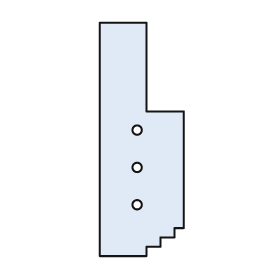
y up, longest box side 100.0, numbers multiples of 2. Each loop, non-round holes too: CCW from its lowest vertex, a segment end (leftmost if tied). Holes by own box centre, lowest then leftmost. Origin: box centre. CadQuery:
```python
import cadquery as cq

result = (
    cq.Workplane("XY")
    .moveTo(-18.0, -50.0)
    .lineTo(2.0, -50.0)
    .lineTo(2.0, -46.0)
    .lineTo(8.0, -46.0)
    .lineTo(8.0, -42.0)
    .lineTo(14.0, -42.0)
    .lineTo(14.0, -38.0)
    .lineTo(18.0, -38.0)
    .lineTo(18.0, 12.0)
    .lineTo(2.0, 12.0)
    .lineTo(2.0, 50.0)
    .lineTo(-18.0, 50.0)
    .close()
    .moveTo(-2.0, -28.0)
    .circle(2.0)
    .moveTo(-2.0, -12.0)
    .circle(2.0)
    .moveTo(-2.0, 4.0)
    .circle(2.0)
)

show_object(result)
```